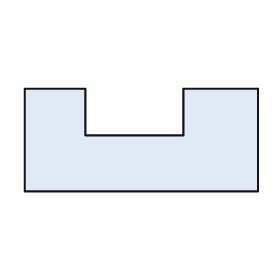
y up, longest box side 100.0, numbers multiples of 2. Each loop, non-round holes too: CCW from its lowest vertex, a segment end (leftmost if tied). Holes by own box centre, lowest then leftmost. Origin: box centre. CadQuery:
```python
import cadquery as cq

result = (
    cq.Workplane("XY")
    .moveTo(-50.0, -22.0)
    .lineTo(50.0, -22.0)
    .lineTo(50.0, 22.0)
    .lineTo(18.0, 22.0)
    .lineTo(18.0, 2.0)
    .lineTo(-24.0, 2.0)
    .lineTo(-24.0, 22.0)
    .lineTo(-50.0, 22.0)
    .close()
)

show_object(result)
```